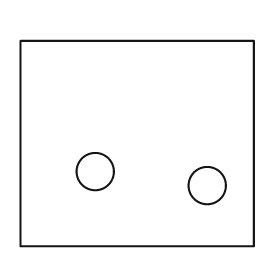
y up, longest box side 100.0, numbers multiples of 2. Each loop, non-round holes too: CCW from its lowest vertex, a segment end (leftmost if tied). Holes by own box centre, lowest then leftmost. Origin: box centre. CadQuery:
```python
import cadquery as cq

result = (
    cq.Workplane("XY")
    .moveTo(-50.0, -44.0)
    .lineTo(50.0, -44.0)
    .lineTo(50.0, 44.0)
    .lineTo(-50.0, 44.0)
    .close()
    .moveTo(30.0, -18.0)
    .circle(8.0)
    .moveTo(-18.0, -12.0)
    .circle(8.0)
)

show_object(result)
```